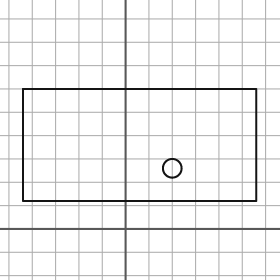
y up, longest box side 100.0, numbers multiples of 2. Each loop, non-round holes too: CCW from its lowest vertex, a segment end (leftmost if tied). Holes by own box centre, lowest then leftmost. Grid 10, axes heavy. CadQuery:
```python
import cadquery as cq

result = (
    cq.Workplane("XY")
    .moveTo(-44.0, 12.0)
    .lineTo(56.0, 12.0)
    .lineTo(56.0, 60.0)
    .lineTo(-44.0, 60.0)
    .close()
    .moveTo(20.0, 26.0)
    .circle(4.0)
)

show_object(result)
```